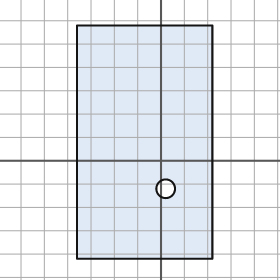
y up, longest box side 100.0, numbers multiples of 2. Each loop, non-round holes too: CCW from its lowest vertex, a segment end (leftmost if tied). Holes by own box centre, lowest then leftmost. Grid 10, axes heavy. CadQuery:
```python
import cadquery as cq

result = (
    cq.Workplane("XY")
    .moveTo(-36.0, -42.0)
    .lineTo(22.0, -42.0)
    .lineTo(22.0, 58.0)
    .lineTo(-36.0, 58.0)
    .close()
    .moveTo(2.0, -12.0)
    .circle(4.0)
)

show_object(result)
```